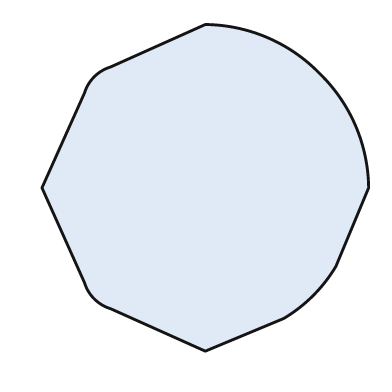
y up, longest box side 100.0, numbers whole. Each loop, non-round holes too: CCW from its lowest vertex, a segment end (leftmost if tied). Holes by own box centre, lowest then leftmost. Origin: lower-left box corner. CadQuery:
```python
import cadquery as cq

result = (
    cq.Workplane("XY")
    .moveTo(50.0, 0.0)
    .lineTo(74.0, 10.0)
    .threePointArc((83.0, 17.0), (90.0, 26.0))
    .lineTo(100.0, 50.0)
    .threePointArc((96.0, 69.0), (85.0, 85.0))
    .threePointArc((69.0, 96.0), (50.0, 100.0))
    .lineTo(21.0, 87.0)
    .threePointArc((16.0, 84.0), (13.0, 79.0))
    .lineTo(0.0, 50.0)
    .lineTo(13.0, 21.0)
    .threePointArc((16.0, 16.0), (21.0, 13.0))
    .close()
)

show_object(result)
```